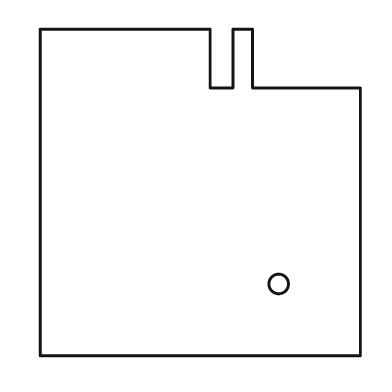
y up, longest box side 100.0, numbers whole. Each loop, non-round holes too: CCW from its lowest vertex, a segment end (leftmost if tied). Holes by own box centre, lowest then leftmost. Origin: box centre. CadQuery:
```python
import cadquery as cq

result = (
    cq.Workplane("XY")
    .moveTo(-49.0, -50.0)
    .lineTo(49.0, -50.0)
    .lineTo(49.0, 32.0)
    .lineTo(16.0, 32.0)
    .lineTo(16.0, 50.0)
    .lineTo(10.0, 50.0)
    .lineTo(10.0, 32.0)
    .lineTo(3.0, 32.0)
    .lineTo(3.0, 50.0)
    .lineTo(-49.0, 50.0)
    .close()
    .moveTo(24.0, -28.0)
    .circle(3.0)
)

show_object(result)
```